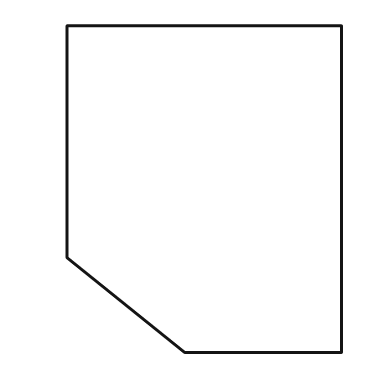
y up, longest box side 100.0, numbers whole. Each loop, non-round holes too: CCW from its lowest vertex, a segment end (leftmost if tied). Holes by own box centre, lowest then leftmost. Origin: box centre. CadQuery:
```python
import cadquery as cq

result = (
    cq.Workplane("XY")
    .moveTo(-6.0, -50.0)
    .lineTo(42.0, -50.0)
    .lineTo(42.0, 50.0)
    .lineTo(-42.0, 50.0)
    .lineTo(-42.0, -21.0)
    .close()
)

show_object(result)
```